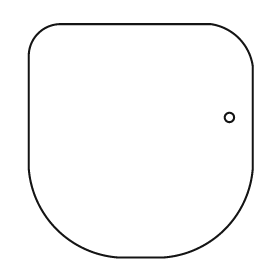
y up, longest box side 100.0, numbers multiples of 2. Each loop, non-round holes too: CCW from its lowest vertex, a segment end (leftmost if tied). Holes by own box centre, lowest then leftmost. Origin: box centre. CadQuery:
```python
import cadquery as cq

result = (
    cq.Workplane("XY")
    .moveTo(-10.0, -50.0)
    .lineTo(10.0, -50.0)
    .threePointArc((36.0, -38.0), (48.0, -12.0))
    .lineTo(48.0, 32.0)
    .threePointArc((42.0, 44.0), (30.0, 50.0))
    .lineTo(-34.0, 50.0)
    .threePointArc((-44.0, 46.0), (-48.0, 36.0))
    .lineTo(-48.0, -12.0)
    .threePointArc((-36.0, -38.0), (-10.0, -50.0))
    .close()
    .moveTo(38.0, 10.0)
    .circle(2.0)
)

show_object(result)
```